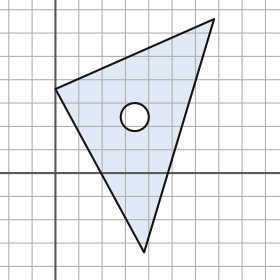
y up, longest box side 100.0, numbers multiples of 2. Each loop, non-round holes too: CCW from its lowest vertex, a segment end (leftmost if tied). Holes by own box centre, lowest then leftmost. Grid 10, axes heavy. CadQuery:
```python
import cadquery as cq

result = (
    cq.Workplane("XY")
    .moveTo(38.0, -34.0)
    .lineTo(68.0, 66.0)
    .lineTo(0.0, 36.0)
    .close()
    .moveTo(34.0, 24.0)
    .circle(6.0)
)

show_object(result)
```